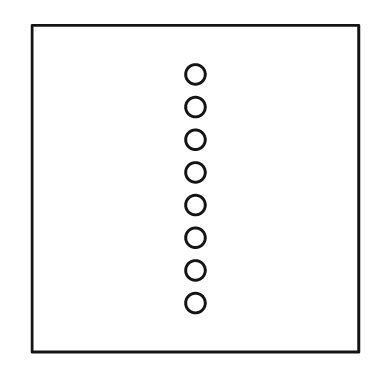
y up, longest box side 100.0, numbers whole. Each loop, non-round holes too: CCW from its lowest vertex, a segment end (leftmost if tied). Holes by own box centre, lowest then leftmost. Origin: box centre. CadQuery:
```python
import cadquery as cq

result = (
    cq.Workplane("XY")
    .moveTo(-50.0, -50.0)
    .lineTo(50.0, -50.0)
    .lineTo(50.0, 50.0)
    .lineTo(-50.0, 50.0)
    .close()
    .moveTo(0.0, -35.0)
    .circle(3.0)
    .moveTo(0.0, -25.0)
    .circle(3.0)
    .moveTo(0.0, -15.0)
    .circle(3.0)
    .moveTo(0.0, -5.0)
    .circle(3.0)
    .moveTo(0.0, 5.0)
    .circle(3.0)
    .moveTo(0.0, 15.0)
    .circle(3.0)
    .moveTo(0.0, 25.0)
    .circle(3.0)
    .moveTo(0.0, 35.0)
    .circle(3.0)
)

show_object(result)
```